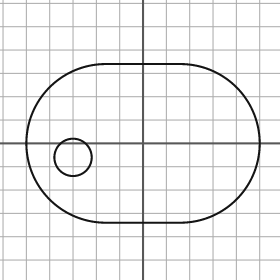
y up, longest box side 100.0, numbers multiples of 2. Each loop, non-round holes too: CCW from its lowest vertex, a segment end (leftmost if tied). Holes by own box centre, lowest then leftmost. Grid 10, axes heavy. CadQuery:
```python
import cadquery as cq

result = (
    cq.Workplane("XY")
    .moveTo(-16.0, -34.0)
    .lineTo(16.0, -34.0)
    .threePointArc((50.0, 0.0), (16.0, 34.0))
    .lineTo(-16.0, 34.0)
    .threePointArc((-50.0, 0.0), (-16.0, -34.0))
    .close()
    .moveTo(-30.0, -6.0)
    .circle(8.0)
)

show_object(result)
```